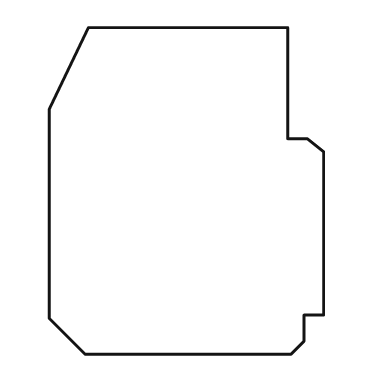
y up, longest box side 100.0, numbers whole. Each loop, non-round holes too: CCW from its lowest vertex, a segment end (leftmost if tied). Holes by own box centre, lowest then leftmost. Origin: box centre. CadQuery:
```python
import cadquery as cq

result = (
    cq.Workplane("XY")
    .moveTo(-31.0, -50.0)
    .lineTo(32.0, -50.0)
    .lineTo(36.0, -46.0)
    .lineTo(36.0, -38.0)
    .lineTo(42.0, -38.0)
    .lineTo(42.0, 12.0)
    .lineTo(37.0, 16.0)
    .lineTo(31.0, 16.0)
    .lineTo(31.0, 50.0)
    .lineTo(-30.0, 50.0)
    .lineTo(-42.0, 25.0)
    .lineTo(-42.0, -39.0)
    .close()
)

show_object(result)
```